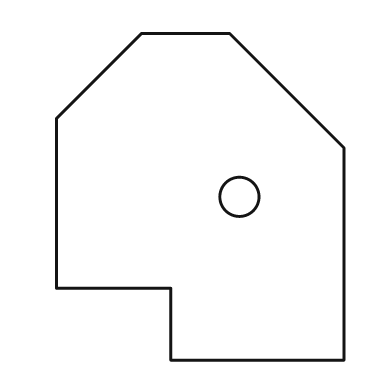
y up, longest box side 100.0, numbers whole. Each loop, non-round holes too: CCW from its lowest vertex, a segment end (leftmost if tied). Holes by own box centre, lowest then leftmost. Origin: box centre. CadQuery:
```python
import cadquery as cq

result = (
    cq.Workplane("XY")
    .moveTo(-9.0, -50.0)
    .lineTo(44.0, -50.0)
    .lineTo(44.0, 15.0)
    .lineTo(9.0, 50.0)
    .lineTo(-18.0, 50.0)
    .lineTo(-44.0, 24.0)
    .lineTo(-44.0, -28.0)
    .lineTo(-9.0, -28.0)
    .close()
    .moveTo(12.0, 0.0)
    .circle(6.0)
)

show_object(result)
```